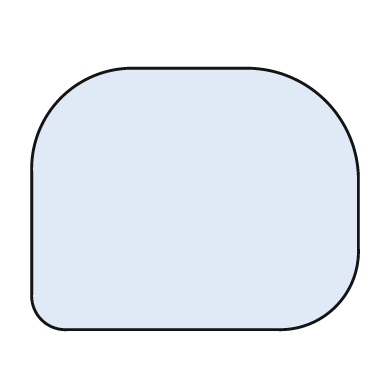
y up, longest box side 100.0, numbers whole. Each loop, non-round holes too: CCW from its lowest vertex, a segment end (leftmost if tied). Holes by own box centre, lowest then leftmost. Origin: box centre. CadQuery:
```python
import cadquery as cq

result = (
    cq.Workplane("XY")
    .moveTo(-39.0, -40.0)
    .lineTo(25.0, -40.0)
    .threePointArc((43.0, -33.0), (50.0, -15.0))
    .lineTo(50.0, 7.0)
    .threePointArc((40.0, 30.0), (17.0, 40.0))
    .lineTo(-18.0, 40.0)
    .threePointArc((-41.0, 31.0), (-50.0, 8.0))
    .lineTo(-50.0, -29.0)
    .threePointArc((-47.0, -37.0), (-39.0, -40.0))
    .close()
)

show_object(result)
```